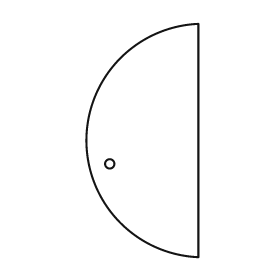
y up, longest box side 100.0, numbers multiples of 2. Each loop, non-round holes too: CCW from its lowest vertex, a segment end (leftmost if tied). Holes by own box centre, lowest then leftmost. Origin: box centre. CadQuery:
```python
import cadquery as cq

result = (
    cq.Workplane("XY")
    .moveTo(24.0, -50.0)
    .lineTo(24.0, 50.0)
    .threePointArc((-24.0, 0.0), (24.0, -50.0))
    .close()
    .moveTo(-14.0, -10.0)
    .circle(2.0)
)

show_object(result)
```